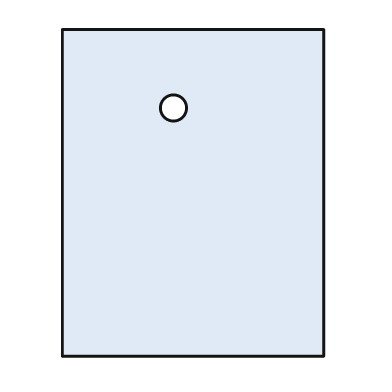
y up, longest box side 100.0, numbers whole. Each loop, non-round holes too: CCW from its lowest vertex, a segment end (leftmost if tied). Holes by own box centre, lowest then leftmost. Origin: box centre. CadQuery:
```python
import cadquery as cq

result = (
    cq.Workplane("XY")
    .moveTo(-40.0, -50.0)
    .lineTo(40.0, -50.0)
    .lineTo(40.0, 50.0)
    .lineTo(-40.0, 50.0)
    .close()
    .moveTo(-6.0, 26.0)
    .circle(4.0)
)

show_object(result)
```